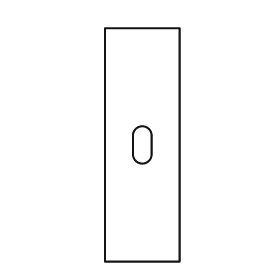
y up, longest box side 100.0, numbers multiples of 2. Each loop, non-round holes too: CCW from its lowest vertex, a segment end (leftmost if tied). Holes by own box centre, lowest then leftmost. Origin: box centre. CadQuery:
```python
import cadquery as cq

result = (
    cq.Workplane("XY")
    .moveTo(-16.0, -50.0)
    .lineTo(16.0, -50.0)
    .lineTo(16.0, 50.0)
    .lineTo(-16.0, 50.0)
    .close()
    .moveTo(-4.0, -4.0)
    .threePointArc((0.0, -8.0), (4.0, -4.0))
    .lineTo(4.0, 4.0)
    .threePointArc((0.0, 8.0), (-4.0, 4.0))
    .close()
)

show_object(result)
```